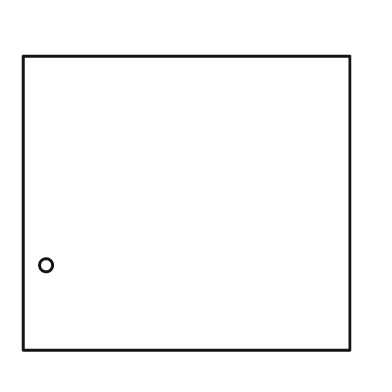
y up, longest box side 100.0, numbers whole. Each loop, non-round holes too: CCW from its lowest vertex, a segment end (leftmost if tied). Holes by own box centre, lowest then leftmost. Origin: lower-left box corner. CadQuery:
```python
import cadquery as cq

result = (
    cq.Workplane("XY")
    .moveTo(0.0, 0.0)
    .lineTo(100.0, 0.0)
    .lineTo(100.0, 90.0)
    .lineTo(0.0, 90.0)
    .close()
    .moveTo(7.0, 26.0)
    .circle(2.0)
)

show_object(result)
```